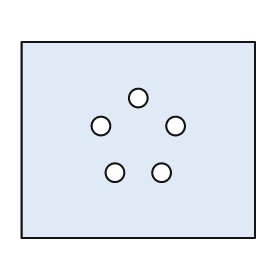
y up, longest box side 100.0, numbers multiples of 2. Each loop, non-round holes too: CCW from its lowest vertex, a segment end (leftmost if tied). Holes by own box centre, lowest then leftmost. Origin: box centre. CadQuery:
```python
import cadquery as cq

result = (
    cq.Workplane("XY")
    .moveTo(-50.0, -42.0)
    .lineTo(50.0, -42.0)
    .lineTo(50.0, 42.0)
    .lineTo(-50.0, 42.0)
    .close()
    .moveTo(-10.0, -14.0)
    .circle(4.0)
    .moveTo(10.0, -14.0)
    .circle(4.0)
    .moveTo(-16.0, 6.0)
    .circle(4.0)
    .moveTo(16.0, 6.0)
    .circle(4.0)
    .moveTo(0.0, 18.0)
    .circle(4.0)
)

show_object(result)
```